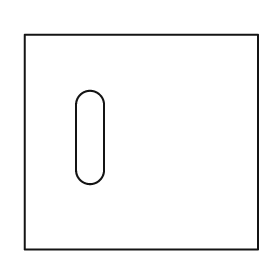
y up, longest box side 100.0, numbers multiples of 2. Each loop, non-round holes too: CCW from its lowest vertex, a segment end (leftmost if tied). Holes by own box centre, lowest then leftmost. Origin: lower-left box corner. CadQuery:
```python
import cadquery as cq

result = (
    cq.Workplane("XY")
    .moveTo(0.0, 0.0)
    .lineTo(100.0, 0.0)
    .lineTo(100.0, 92.0)
    .lineTo(0.0, 92.0)
    .close()
    .moveTo(22.0, 34.0)
    .threePointArc((28.0, 28.0), (34.0, 34.0))
    .lineTo(34.0, 62.0)
    .threePointArc((28.0, 68.0), (22.0, 62.0))
    .close()
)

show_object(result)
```